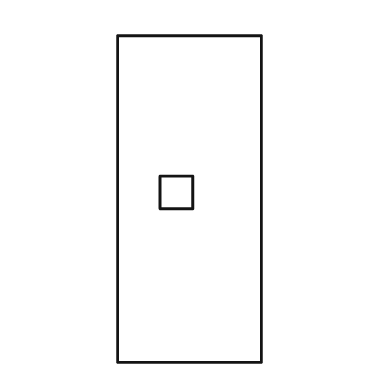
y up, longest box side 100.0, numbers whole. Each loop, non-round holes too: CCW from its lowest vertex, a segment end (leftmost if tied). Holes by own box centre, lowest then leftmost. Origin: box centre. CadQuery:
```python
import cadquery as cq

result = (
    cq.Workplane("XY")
    .moveTo(-22.0, -50.0)
    .lineTo(22.0, -50.0)
    .lineTo(22.0, 50.0)
    .lineTo(-22.0, 50.0)
    .close()
    .moveTo(-9.0, -3.0)
    .lineTo(1.0, -3.0)
    .lineTo(1.0, 7.0)
    .lineTo(-9.0, 7.0)
    .close()
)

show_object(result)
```